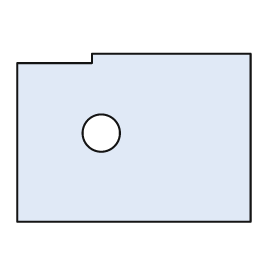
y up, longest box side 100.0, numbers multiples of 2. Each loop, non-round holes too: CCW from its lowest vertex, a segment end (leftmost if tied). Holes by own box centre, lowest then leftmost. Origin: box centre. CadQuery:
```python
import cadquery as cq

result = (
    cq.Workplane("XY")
    .moveTo(-50.0, -36.0)
    .lineTo(50.0, -36.0)
    .lineTo(50.0, 36.0)
    .lineTo(-18.0, 36.0)
    .lineTo(-18.0, 32.0)
    .lineTo(-50.0, 32.0)
    .close()
    .moveTo(-14.0, 2.0)
    .circle(8.0)
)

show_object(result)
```